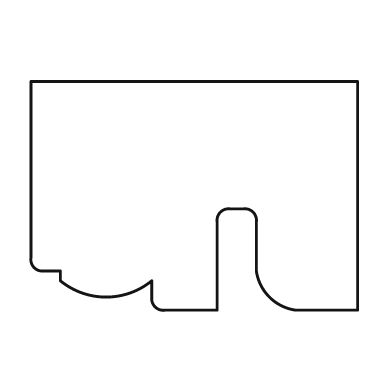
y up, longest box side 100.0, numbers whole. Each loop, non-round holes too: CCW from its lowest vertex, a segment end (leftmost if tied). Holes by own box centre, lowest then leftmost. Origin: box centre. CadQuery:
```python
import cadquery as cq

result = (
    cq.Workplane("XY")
    .moveTo(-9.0, -35.0)
    .lineTo(7.0, -35.0)
    .lineTo(7.0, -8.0)
    .threePointArc((8.0, -5.0), (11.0, -4.0))
    .lineTo(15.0, -4.0)
    .threePointArc((18.0, -5.0), (19.0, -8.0))
    .lineTo(19.0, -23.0)
    .threePointArc((23.0, -31.0), (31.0, -35.0))
    .lineTo(50.0, -35.0)
    .lineTo(50.0, 35.0)
    .lineTo(-50.0, 35.0)
    .lineTo(-50.0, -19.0)
    .threePointArc((-49.0, -22.0), (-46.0, -23.0))
    .lineTo(-41.0, -23.0)
    .lineTo(-41.0, -26.0)
    .threePointArc((-27.0, -31.0), (-13.0, -26.0))
    .lineTo(-13.0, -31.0)
    .threePointArc((-12.0, -34.0), (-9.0, -35.0))
    .close()
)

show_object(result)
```